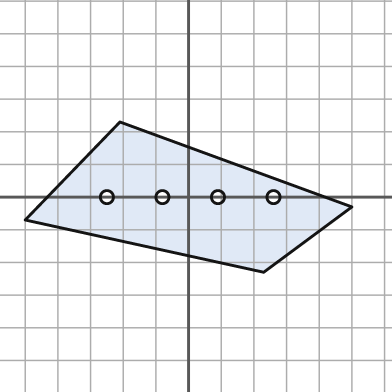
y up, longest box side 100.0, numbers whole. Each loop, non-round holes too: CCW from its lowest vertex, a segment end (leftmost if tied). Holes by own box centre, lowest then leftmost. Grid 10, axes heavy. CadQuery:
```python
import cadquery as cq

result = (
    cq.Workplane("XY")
    .moveTo(23.0, -23.0)
    .lineTo(50.0, -3.0)
    .lineTo(-21.0, 23.0)
    .lineTo(-50.0, -7.0)
    .close()
    .moveTo(-25.0, 0.0)
    .circle(2.0)
    .moveTo(-8.0, 0.0)
    .circle(2.0)
    .moveTo(9.0, 0.0)
    .circle(2.0)
    .moveTo(26.0, 0.0)
    .circle(2.0)
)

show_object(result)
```